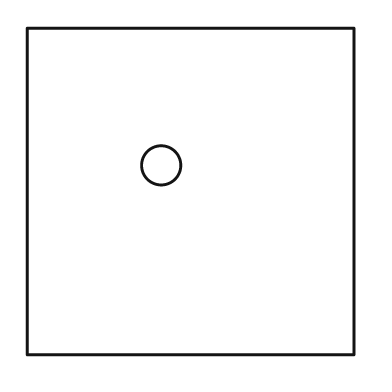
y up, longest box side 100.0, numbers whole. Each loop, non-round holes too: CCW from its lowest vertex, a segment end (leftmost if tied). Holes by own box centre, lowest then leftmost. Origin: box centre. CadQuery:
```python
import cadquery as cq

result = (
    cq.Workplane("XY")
    .moveTo(-50.0, -50.0)
    .lineTo(50.0, -50.0)
    .lineTo(50.0, 50.0)
    .lineTo(-50.0, 50.0)
    .close()
    .moveTo(-9.0, 8.0)
    .circle(6.0)
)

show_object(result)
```